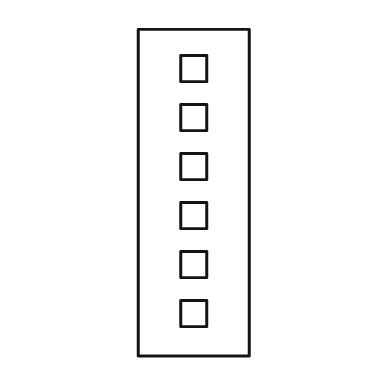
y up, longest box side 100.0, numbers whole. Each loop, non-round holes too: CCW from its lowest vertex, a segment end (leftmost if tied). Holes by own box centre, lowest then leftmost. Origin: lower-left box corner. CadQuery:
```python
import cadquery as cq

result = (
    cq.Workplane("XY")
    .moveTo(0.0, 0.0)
    .lineTo(34.0, 0.0)
    .lineTo(34.0, 100.0)
    .lineTo(0.0, 100.0)
    .close()
    .moveTo(13.0, 9.0)
    .lineTo(21.0, 9.0)
    .lineTo(21.0, 17.0)
    .lineTo(13.0, 17.0)
    .close()
    .moveTo(13.0, 24.0)
    .lineTo(21.0, 24.0)
    .lineTo(21.0, 32.0)
    .lineTo(13.0, 32.0)
    .close()
    .moveTo(13.0, 39.0)
    .lineTo(21.0, 39.0)
    .lineTo(21.0, 47.0)
    .lineTo(13.0, 47.0)
    .close()
    .moveTo(13.0, 54.0)
    .lineTo(21.0, 54.0)
    .lineTo(21.0, 62.0)
    .lineTo(13.0, 62.0)
    .close()
    .moveTo(13.0, 69.0)
    .lineTo(21.0, 69.0)
    .lineTo(21.0, 77.0)
    .lineTo(13.0, 77.0)
    .close()
    .moveTo(13.0, 84.0)
    .lineTo(21.0, 84.0)
    .lineTo(21.0, 92.0)
    .lineTo(13.0, 92.0)
    .close()
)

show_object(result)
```